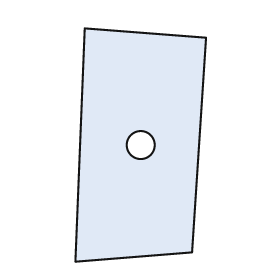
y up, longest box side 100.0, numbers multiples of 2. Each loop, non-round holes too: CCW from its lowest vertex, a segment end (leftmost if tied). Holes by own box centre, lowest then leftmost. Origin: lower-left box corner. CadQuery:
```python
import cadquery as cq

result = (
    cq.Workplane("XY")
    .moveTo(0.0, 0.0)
    .lineTo(50.0, 4.0)
    .lineTo(56.0, 96.0)
    .lineTo(4.0, 100.0)
    .close()
    .moveTo(28.0, 50.0)
    .circle(6.0)
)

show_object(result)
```